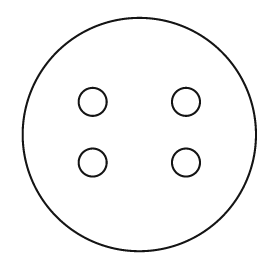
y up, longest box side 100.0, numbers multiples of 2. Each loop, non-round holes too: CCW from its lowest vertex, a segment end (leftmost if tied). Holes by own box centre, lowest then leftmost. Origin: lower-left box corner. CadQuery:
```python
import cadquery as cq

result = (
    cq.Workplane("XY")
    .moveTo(50.0, 50.0)
    .circle(50.0)
    .moveTo(30.0, 38.0)
    .circle(6.0)
    .moveTo(70.0, 38.0)
    .circle(6.0)
    .moveTo(30.0, 64.0)
    .circle(6.0)
    .moveTo(70.0, 64.0)
    .circle(6.0)
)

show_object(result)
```